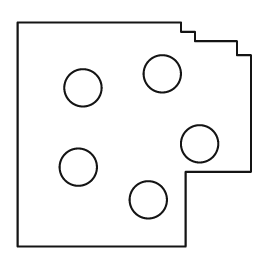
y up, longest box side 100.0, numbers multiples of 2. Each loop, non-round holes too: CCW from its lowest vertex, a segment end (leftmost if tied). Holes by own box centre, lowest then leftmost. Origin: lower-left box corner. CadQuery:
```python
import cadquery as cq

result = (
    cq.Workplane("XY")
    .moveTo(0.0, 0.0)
    .lineTo(72.0, 0.0)
    .lineTo(72.0, 32.0)
    .lineTo(100.0, 32.0)
    .lineTo(100.0, 82.0)
    .lineTo(94.0, 82.0)
    .lineTo(94.0, 88.0)
    .lineTo(76.0, 88.0)
    .lineTo(76.0, 92.0)
    .lineTo(70.0, 92.0)
    .lineTo(70.0, 96.0)
    .lineTo(0.0, 96.0)
    .close()
    .moveTo(56.0, 20.0)
    .circle(8.0)
    .moveTo(26.0, 34.0)
    .circle(8.0)
    .moveTo(78.0, 44.0)
    .circle(8.0)
    .moveTo(28.0, 68.0)
    .circle(8.0)
    .moveTo(62.0, 74.0)
    .circle(8.0)
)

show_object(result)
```